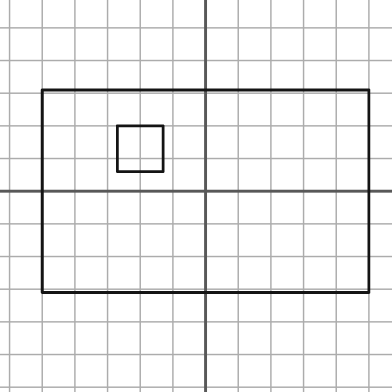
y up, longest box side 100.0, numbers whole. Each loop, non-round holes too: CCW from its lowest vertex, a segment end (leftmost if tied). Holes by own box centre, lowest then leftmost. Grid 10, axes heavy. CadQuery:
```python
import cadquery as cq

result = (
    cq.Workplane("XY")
    .moveTo(-50.0, -31.0)
    .lineTo(50.0, -31.0)
    .lineTo(50.0, 31.0)
    .lineTo(-50.0, 31.0)
    .close()
    .moveTo(-27.0, 6.0)
    .lineTo(-13.0, 6.0)
    .lineTo(-13.0, 20.0)
    .lineTo(-27.0, 20.0)
    .close()
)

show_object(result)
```